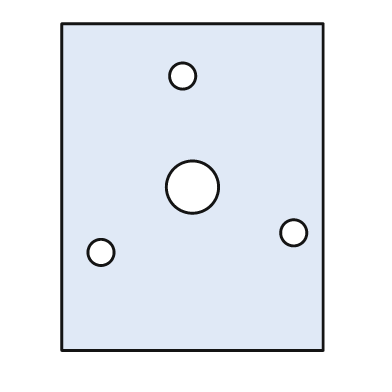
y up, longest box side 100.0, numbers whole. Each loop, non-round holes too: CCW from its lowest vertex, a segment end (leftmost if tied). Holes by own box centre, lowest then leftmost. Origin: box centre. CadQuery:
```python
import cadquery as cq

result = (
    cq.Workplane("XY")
    .moveTo(-40.0, -50.0)
    .lineTo(40.0, -50.0)
    .lineTo(40.0, 50.0)
    .lineTo(-40.0, 50.0)
    .close()
    .moveTo(-28.0, -20.0)
    .circle(4.0)
    .moveTo(31.0, -14.0)
    .circle(4.0)
    .moveTo(0.0, 0.0)
    .circle(8.0)
    .moveTo(-3.0, 34.0)
    .circle(4.0)
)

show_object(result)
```